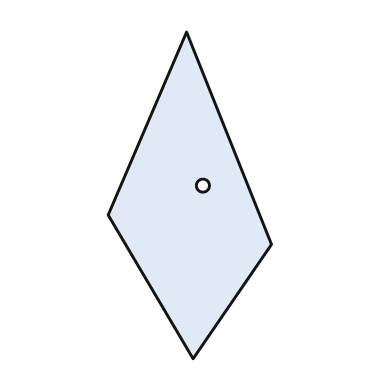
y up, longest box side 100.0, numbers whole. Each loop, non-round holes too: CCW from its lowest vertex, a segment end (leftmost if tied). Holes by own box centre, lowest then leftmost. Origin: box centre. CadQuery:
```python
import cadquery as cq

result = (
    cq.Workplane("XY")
    .moveTo(1.0, -50.0)
    .lineTo(25.0, -15.0)
    .lineTo(-1.0, 50.0)
    .lineTo(-25.0, -6.0)
    .close()
    .moveTo(4.0, 3.0)
    .circle(2.0)
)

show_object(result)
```